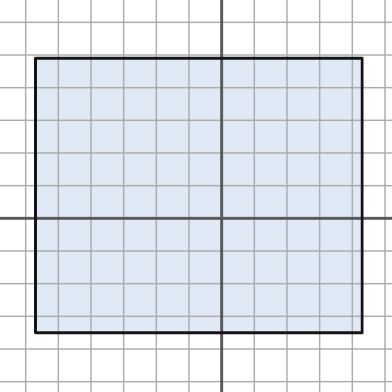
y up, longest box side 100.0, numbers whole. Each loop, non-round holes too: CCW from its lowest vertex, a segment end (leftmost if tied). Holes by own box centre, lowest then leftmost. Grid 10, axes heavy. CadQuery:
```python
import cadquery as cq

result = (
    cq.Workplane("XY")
    .moveTo(-57.0, -35.0)
    .lineTo(43.0, -35.0)
    .lineTo(43.0, 49.0)
    .lineTo(-57.0, 49.0)
    .close()
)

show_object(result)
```